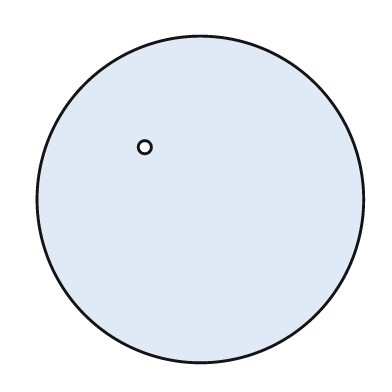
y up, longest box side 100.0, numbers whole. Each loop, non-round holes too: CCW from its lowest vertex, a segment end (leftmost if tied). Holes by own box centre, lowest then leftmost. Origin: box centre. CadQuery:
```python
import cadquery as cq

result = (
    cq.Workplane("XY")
    .moveTo(0.0, 0.0)
    .circle(50.0)
    .moveTo(-17.0, 16.0)
    .circle(2.0)
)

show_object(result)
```